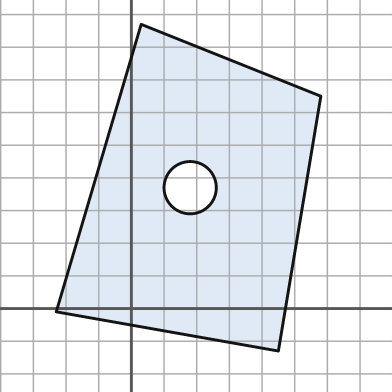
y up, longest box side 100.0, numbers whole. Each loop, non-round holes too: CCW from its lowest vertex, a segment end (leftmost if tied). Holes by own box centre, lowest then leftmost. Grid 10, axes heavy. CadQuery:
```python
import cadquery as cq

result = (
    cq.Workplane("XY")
    .moveTo(45.0, -13.0)
    .lineTo(58.0, 65.0)
    .lineTo(3.0, 87.0)
    .lineTo(-23.0, -1.0)
    .close()
    .moveTo(18.0, 37.0)
    .circle(8.0)
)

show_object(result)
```